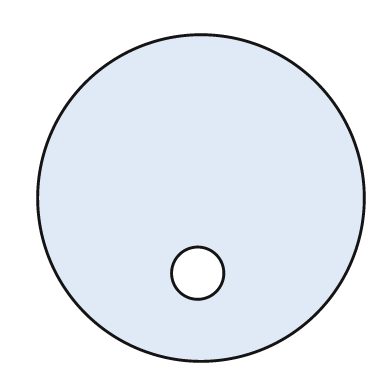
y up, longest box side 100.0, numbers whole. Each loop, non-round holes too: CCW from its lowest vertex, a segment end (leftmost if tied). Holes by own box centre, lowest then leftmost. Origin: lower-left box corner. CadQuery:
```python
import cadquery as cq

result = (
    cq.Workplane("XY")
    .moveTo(50.0, 50.0)
    .circle(50.0)
    .moveTo(49.0, 27.0)
    .circle(8.0)
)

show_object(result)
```